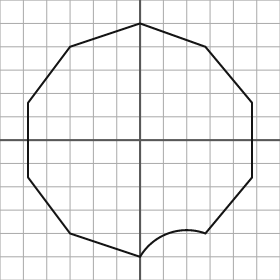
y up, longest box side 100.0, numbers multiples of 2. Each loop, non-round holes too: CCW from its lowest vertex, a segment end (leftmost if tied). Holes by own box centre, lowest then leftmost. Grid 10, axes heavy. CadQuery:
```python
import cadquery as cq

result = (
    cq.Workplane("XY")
    .moveTo(0.0, -50.0)
    .threePointArc((12.0, -40.0), (28.0, -40.0))
    .lineTo(48.0, -16.0)
    .lineTo(48.0, 16.0)
    .lineTo(28.0, 40.0)
    .lineTo(0.0, 50.0)
    .lineTo(-30.0, 40.0)
    .lineTo(-48.0, 16.0)
    .lineTo(-48.0, -16.0)
    .lineTo(-30.0, -40.0)
    .close()
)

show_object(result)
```